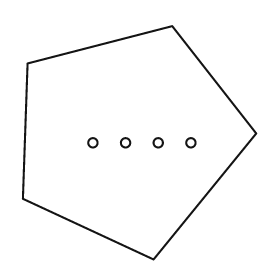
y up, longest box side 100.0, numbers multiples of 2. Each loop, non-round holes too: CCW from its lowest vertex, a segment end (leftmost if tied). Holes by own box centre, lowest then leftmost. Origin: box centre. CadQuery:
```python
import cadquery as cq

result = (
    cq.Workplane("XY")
    .moveTo(6.0, -50.0)
    .lineTo(50.0, 4.0)
    .lineTo(14.0, 50.0)
    .lineTo(-48.0, 34.0)
    .lineTo(-50.0, -24.0)
    .close()
    .moveTo(-20.0, 0.0)
    .circle(2.0)
    .moveTo(-6.0, 0.0)
    .circle(2.0)
    .moveTo(8.0, 0.0)
    .circle(2.0)
    .moveTo(22.0, 0.0)
    .circle(2.0)
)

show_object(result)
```